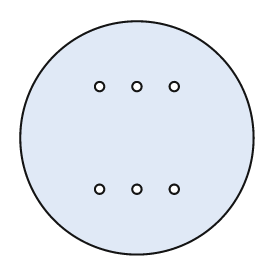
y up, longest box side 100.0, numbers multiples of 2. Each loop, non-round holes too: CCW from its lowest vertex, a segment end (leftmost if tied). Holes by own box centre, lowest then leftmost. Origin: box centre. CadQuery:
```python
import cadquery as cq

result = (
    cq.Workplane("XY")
    .moveTo(0.0, 0.0)
    .circle(50.0)
    .moveTo(-16.0, -22.0)
    .circle(2.0)
    .moveTo(0.0, -22.0)
    .circle(2.0)
    .moveTo(16.0, -22.0)
    .circle(2.0)
    .moveTo(-16.0, 22.0)
    .circle(2.0)
    .moveTo(0.0, 22.0)
    .circle(2.0)
    .moveTo(16.0, 22.0)
    .circle(2.0)
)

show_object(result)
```